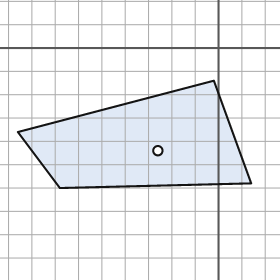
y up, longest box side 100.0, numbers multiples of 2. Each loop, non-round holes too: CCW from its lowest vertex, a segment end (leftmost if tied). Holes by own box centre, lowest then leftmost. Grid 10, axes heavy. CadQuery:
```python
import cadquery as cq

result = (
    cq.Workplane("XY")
    .moveTo(-68.0, -60.0)
    .lineTo(14.0, -58.0)
    .lineTo(-2.0, -14.0)
    .lineTo(-86.0, -36.0)
    .close()
    .moveTo(-26.0, -44.0)
    .circle(2.0)
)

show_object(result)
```